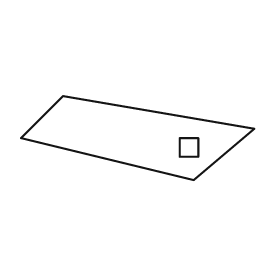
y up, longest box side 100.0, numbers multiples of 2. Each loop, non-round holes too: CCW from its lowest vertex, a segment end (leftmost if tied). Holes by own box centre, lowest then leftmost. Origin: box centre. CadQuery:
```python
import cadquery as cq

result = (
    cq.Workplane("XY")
    .moveTo(24.0, -18.0)
    .lineTo(50.0, 4.0)
    .lineTo(-32.0, 18.0)
    .lineTo(-50.0, 0.0)
    .close()
    .moveTo(18.0, -8.0)
    .lineTo(26.0, -8.0)
    .lineTo(26.0, 0.0)
    .lineTo(18.0, 0.0)
    .close()
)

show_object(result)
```